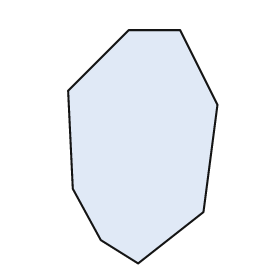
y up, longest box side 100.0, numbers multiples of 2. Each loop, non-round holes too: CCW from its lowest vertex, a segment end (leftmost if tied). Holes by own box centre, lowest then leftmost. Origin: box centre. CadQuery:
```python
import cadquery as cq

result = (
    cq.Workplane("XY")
    .moveTo(-2.0, -50.0)
    .lineTo(26.0, -28.0)
    .lineTo(32.0, 18.0)
    .lineTo(16.0, 50.0)
    .lineTo(-6.0, 50.0)
    .lineTo(-32.0, 24.0)
    .lineTo(-30.0, -18.0)
    .lineTo(-18.0, -40.0)
    .close()
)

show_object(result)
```